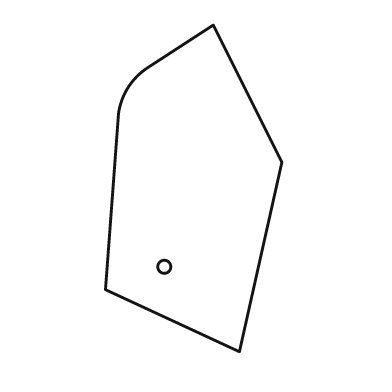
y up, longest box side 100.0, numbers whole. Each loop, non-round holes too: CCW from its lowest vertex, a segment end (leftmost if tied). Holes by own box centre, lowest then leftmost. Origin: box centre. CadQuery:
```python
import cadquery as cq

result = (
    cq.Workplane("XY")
    .moveTo(14.0, -50.0)
    .lineTo(27.0, 8.0)
    .lineTo(6.0, 50.0)
    .lineTo(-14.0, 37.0)
    .threePointArc((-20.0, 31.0), (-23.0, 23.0))
    .lineTo(-27.0, -31.0)
    .close()
    .moveTo(-9.0, -24.0)
    .circle(2.0)
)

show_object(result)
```